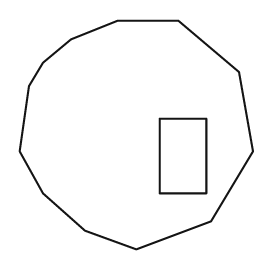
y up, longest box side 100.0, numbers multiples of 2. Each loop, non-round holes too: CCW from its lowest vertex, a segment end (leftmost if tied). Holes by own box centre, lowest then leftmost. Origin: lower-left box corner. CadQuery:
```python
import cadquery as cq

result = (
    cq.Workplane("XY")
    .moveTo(50.0, 0.0)
    .lineTo(82.0, 12.0)
    .lineTo(100.0, 42.0)
    .lineTo(94.0, 76.0)
    .lineTo(68.0, 98.0)
    .lineTo(42.0, 98.0)
    .lineTo(22.0, 90.0)
    .lineTo(10.0, 80.0)
    .lineTo(4.0, 70.0)
    .lineTo(0.0, 42.0)
    .lineTo(10.0, 24.0)
    .lineTo(28.0, 8.0)
    .close()
    .moveTo(60.0, 24.0)
    .lineTo(80.0, 24.0)
    .lineTo(80.0, 56.0)
    .lineTo(60.0, 56.0)
    .close()
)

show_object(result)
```